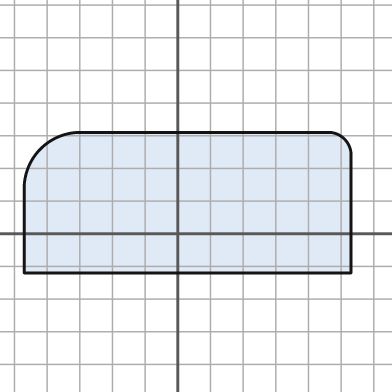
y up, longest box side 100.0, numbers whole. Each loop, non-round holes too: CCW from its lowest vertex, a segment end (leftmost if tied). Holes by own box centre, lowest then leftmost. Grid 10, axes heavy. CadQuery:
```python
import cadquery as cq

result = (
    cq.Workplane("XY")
    .moveTo(-47.0, -12.0)
    .lineTo(53.0, -12.0)
    .lineTo(53.0, 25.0)
    .threePointArc((51.0, 29.0), (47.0, 31.0))
    .lineTo(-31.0, 31.0)
    .threePointArc((-42.0, 26.0), (-47.0, 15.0))
    .close()
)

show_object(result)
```